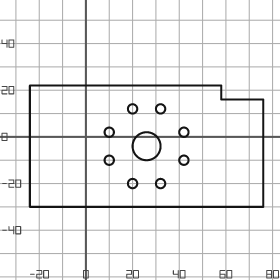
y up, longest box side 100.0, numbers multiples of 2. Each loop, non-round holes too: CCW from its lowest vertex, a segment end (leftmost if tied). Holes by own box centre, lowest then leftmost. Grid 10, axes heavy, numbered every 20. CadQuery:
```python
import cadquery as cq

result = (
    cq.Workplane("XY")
    .moveTo(-24.0, -30.0)
    .lineTo(76.0, -30.0)
    .lineTo(76.0, 16.0)
    .lineTo(58.0, 16.0)
    .lineTo(58.0, 22.0)
    .lineTo(-24.0, 22.0)
    .close()
    .moveTo(20.0, -20.0)
    .circle(2.0)
    .moveTo(32.0, -20.0)
    .circle(2.0)
    .moveTo(10.0, -10.0)
    .circle(2.0)
    .moveTo(42.0, -10.0)
    .circle(2.0)
    .moveTo(26.0, -4.0)
    .circle(6.0)
    .moveTo(10.0, 2.0)
    .circle(2.0)
    .moveTo(42.0, 2.0)
    .circle(2.0)
    .moveTo(20.0, 12.0)
    .circle(2.0)
    .moveTo(32.0, 12.0)
    .circle(2.0)
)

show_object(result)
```